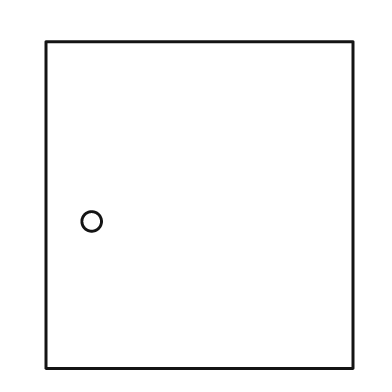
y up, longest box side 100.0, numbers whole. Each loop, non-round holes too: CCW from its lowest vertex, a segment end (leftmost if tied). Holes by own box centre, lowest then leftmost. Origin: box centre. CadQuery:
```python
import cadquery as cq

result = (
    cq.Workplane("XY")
    .moveTo(-47.0, -50.0)
    .lineTo(47.0, -50.0)
    .lineTo(47.0, 50.0)
    .lineTo(-47.0, 50.0)
    .close()
    .moveTo(-33.0, -5.0)
    .circle(3.0)
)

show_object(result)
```